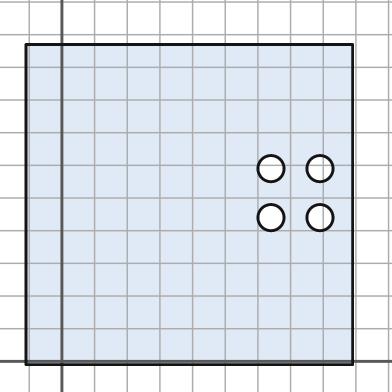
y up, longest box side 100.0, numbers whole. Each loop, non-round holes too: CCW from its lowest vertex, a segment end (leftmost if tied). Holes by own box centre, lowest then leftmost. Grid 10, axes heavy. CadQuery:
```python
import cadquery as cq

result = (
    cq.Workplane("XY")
    .moveTo(-11.0, -1.0)
    .lineTo(89.0, -1.0)
    .lineTo(89.0, 97.0)
    .lineTo(-11.0, 97.0)
    .close()
    .moveTo(64.0, 44.0)
    .circle(4.0)
    .moveTo(79.0, 44.0)
    .circle(4.0)
    .moveTo(64.0, 59.0)
    .circle(4.0)
    .moveTo(79.0, 59.0)
    .circle(4.0)
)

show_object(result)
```